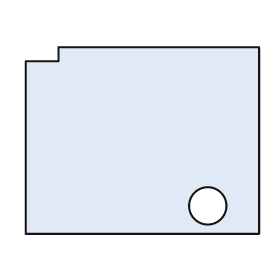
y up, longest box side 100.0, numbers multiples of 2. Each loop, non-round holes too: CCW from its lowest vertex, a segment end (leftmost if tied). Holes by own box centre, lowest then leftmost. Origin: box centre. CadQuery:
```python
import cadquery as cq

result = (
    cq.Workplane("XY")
    .moveTo(-50.0, -40.0)
    .lineTo(50.0, -40.0)
    .lineTo(50.0, 40.0)
    .lineTo(-36.0, 40.0)
    .lineTo(-36.0, 34.0)
    .lineTo(-50.0, 34.0)
    .close()
    .moveTo(28.0, -28.0)
    .circle(8.0)
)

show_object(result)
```